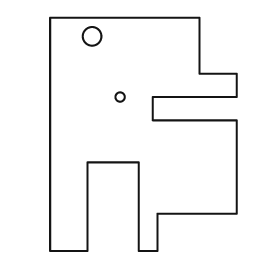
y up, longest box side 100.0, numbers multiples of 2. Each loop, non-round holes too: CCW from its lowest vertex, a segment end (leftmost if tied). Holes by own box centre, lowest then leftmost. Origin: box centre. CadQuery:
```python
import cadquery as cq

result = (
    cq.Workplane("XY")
    .moveTo(-40.0, -50.0)
    .lineTo(-24.0, -50.0)
    .lineTo(-24.0, -12.0)
    .lineTo(-2.0, -12.0)
    .lineTo(-2.0, -50.0)
    .lineTo(6.0, -50.0)
    .lineTo(6.0, -34.0)
    .lineTo(40.0, -34.0)
    .lineTo(40.0, 6.0)
    .lineTo(4.0, 6.0)
    .lineTo(4.0, 16.0)
    .lineTo(40.0, 16.0)
    .lineTo(40.0, 26.0)
    .lineTo(24.0, 26.0)
    .lineTo(24.0, 50.0)
    .lineTo(-40.0, 50.0)
    .close()
    .moveTo(-10.0, 16.0)
    .circle(2.0)
    .moveTo(-22.0, 42.0)
    .circle(4.0)
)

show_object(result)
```